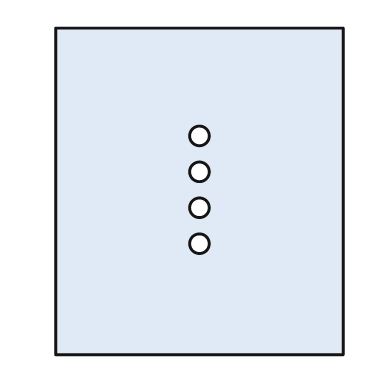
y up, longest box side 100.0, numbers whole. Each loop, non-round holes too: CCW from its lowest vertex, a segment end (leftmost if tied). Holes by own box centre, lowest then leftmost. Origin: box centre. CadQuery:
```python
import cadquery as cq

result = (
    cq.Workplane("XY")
    .moveTo(-44.0, -50.0)
    .lineTo(44.0, -50.0)
    .lineTo(44.0, 50.0)
    .lineTo(-44.0, 50.0)
    .close()
    .moveTo(0.0, -16.0)
    .circle(3.0)
    .moveTo(0.0, -5.0)
    .circle(3.0)
    .moveTo(0.0, 6.0)
    .circle(3.0)
    .moveTo(0.0, 17.0)
    .circle(3.0)
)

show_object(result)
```